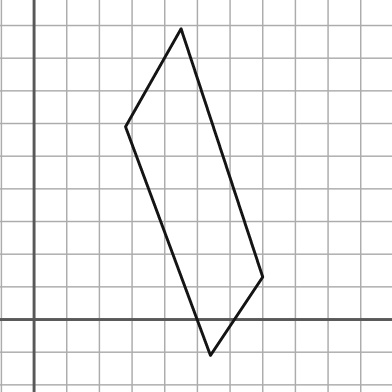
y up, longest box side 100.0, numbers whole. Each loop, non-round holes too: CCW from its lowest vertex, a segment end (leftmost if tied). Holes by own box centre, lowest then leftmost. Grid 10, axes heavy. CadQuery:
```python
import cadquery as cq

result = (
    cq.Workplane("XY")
    .moveTo(54.0, -11.0)
    .lineTo(70.0, 13.0)
    .lineTo(45.0, 89.0)
    .lineTo(28.0, 59.0)
    .close()
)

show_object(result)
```